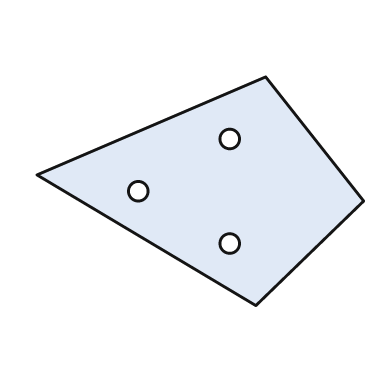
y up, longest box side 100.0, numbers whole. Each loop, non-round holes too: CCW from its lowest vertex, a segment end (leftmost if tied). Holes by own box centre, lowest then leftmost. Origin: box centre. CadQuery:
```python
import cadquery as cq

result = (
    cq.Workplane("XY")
    .moveTo(17.0, -35.0)
    .lineTo(50.0, -3.0)
    .lineTo(20.0, 35.0)
    .lineTo(-50.0, 5.0)
    .close()
    .moveTo(9.0, -16.0)
    .circle(3.0)
    .moveTo(-19.0, 0.0)
    .circle(3.0)
    .moveTo(9.0, 16.0)
    .circle(3.0)
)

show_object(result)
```